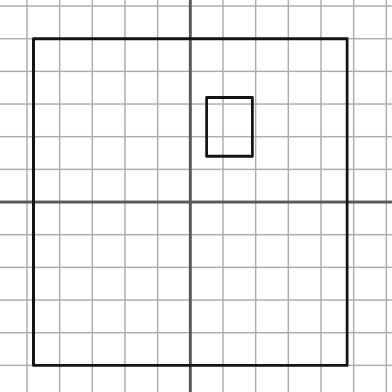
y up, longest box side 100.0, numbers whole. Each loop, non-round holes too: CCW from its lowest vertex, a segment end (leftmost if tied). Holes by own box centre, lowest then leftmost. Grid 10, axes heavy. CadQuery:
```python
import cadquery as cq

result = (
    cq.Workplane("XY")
    .moveTo(-48.0, -50.0)
    .lineTo(48.0, -50.0)
    .lineTo(48.0, 50.0)
    .lineTo(-48.0, 50.0)
    .close()
    .moveTo(5.0, 14.0)
    .lineTo(19.0, 14.0)
    .lineTo(19.0, 32.0)
    .lineTo(5.0, 32.0)
    .close()
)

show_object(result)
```